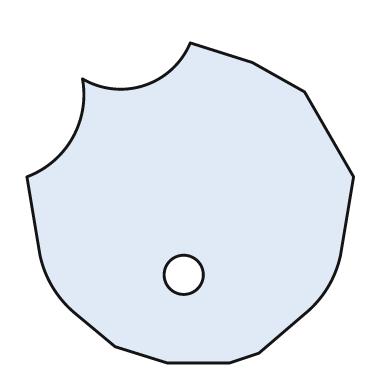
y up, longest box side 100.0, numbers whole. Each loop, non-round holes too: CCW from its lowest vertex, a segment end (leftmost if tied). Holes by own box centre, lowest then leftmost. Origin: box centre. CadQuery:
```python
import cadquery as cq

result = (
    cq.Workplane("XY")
    .moveTo(-7.0, -49.0)
    .lineTo(12.0, -49.0)
    .lineTo(21.0, -46.0)
    .lineTo(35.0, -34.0)
    .threePointArc((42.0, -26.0), (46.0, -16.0))
    .lineTo(50.0, 8.0)
    .lineTo(35.0, 34.0)
    .lineTo(19.0, 43.0)
    .lineTo(0.0, 49.0)
    .threePointArc((-14.0, 36.0), (-33.0, 38.0))
    .threePointArc((-36.0, 20.0), (-50.0, 8.0))
    .lineTo(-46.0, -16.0)
    .threePointArc((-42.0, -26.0), (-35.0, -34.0))
    .lineTo(-23.0, -44.0)
    .close()
    .moveTo(-2.0, -22.0)
    .circle(6.0)
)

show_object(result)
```